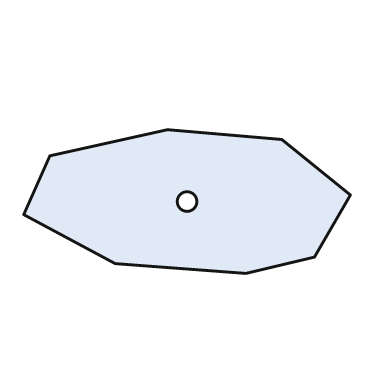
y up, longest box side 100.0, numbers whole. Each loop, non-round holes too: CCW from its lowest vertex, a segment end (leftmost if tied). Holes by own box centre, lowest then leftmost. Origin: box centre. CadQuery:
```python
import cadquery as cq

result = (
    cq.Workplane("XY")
    .moveTo(18.0, -22.0)
    .lineTo(39.0, -17.0)
    .lineTo(50.0, 2.0)
    .lineTo(29.0, 19.0)
    .lineTo(-6.0, 22.0)
    .lineTo(-42.0, 14.0)
    .lineTo(-50.0, -4.0)
    .lineTo(-22.0, -19.0)
    .close()
    .moveTo(0.0, 0.0)
    .circle(3.0)
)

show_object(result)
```